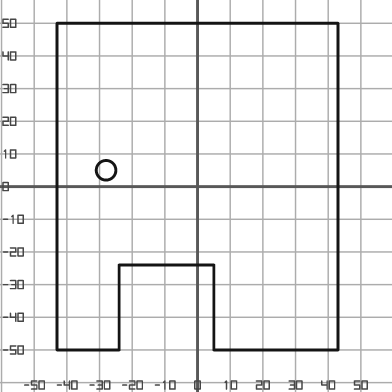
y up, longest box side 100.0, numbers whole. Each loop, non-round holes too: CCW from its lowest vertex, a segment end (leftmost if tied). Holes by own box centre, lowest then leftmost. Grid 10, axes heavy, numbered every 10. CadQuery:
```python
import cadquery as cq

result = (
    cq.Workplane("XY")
    .moveTo(-43.0, -50.0)
    .lineTo(-24.0, -50.0)
    .lineTo(-24.0, -24.0)
    .lineTo(5.0, -24.0)
    .lineTo(5.0, -50.0)
    .lineTo(43.0, -50.0)
    .lineTo(43.0, 50.0)
    .lineTo(-43.0, 50.0)
    .close()
    .moveTo(-28.0, 5.0)
    .circle(3.0)
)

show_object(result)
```